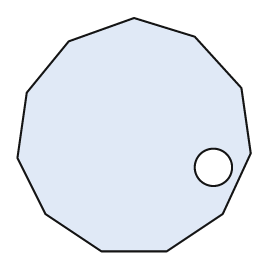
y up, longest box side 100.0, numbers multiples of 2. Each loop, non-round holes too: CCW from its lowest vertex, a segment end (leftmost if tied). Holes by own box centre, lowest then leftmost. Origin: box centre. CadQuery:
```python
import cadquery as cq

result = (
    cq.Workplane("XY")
    .moveTo(-14.0, -50.0)
    .lineTo(14.0, -50.0)
    .lineTo(38.0, -34.0)
    .lineTo(50.0, -8.0)
    .lineTo(46.0, 20.0)
    .lineTo(26.0, 42.0)
    .lineTo(0.0, 50.0)
    .lineTo(-28.0, 40.0)
    .lineTo(-46.0, 18.0)
    .lineTo(-50.0, -10.0)
    .lineTo(-38.0, -34.0)
    .close()
    .moveTo(34.0, -14.0)
    .circle(8.0)
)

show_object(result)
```